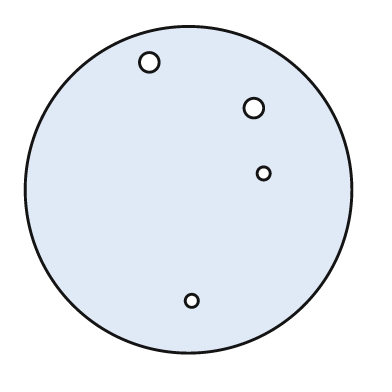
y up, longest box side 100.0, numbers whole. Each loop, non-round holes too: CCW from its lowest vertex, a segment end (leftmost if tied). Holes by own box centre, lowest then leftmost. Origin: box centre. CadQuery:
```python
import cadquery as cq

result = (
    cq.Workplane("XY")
    .moveTo(0.0, 0.0)
    .circle(50.0)
    .moveTo(1.0, -34.0)
    .circle(2.0)
    .moveTo(23.0, 5.0)
    .circle(2.0)
    .moveTo(20.0, 25.0)
    .circle(3.0)
    .moveTo(-12.0, 39.0)
    .circle(3.0)
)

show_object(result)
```